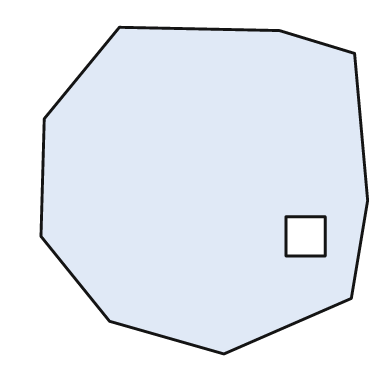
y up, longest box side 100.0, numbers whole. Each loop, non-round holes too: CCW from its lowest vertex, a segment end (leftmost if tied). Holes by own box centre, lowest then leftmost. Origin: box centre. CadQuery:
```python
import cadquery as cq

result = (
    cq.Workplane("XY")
    .moveTo(6.0, -50.0)
    .lineTo(45.0, -33.0)
    .lineTo(50.0, -3.0)
    .lineTo(46.0, 42.0)
    .lineTo(23.0, 49.0)
    .lineTo(-26.0, 50.0)
    .lineTo(-49.0, 22.0)
    .lineTo(-50.0, -14.0)
    .lineTo(-29.0, -40.0)
    .close()
    .moveTo(25.0, -20.0)
    .lineTo(37.0, -20.0)
    .lineTo(37.0, -8.0)
    .lineTo(25.0, -8.0)
    .close()
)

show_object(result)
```